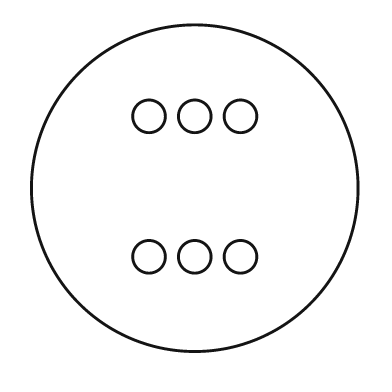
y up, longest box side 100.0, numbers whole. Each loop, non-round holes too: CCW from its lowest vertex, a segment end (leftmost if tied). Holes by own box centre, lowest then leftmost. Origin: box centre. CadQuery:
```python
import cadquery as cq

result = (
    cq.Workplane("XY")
    .moveTo(0.0, 0.0)
    .circle(50.0)
    .moveTo(-14.0, -21.0)
    .circle(5.0)
    .moveTo(0.0, -21.0)
    .circle(5.0)
    .moveTo(14.0, -21.0)
    .circle(5.0)
    .moveTo(-14.0, 22.0)
    .circle(5.0)
    .moveTo(0.0, 22.0)
    .circle(5.0)
    .moveTo(14.0, 22.0)
    .circle(5.0)
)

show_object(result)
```